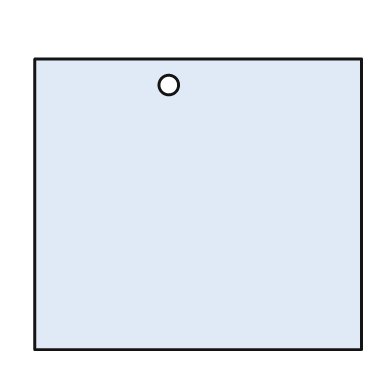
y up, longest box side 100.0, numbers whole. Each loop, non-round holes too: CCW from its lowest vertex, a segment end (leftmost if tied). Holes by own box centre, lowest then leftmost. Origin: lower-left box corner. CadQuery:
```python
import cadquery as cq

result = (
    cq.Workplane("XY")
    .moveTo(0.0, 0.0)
    .lineTo(100.0, 0.0)
    .lineTo(100.0, 89.0)
    .lineTo(0.0, 89.0)
    .close()
    .moveTo(41.0, 81.0)
    .circle(3.0)
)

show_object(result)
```